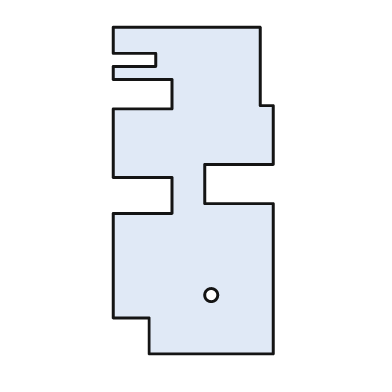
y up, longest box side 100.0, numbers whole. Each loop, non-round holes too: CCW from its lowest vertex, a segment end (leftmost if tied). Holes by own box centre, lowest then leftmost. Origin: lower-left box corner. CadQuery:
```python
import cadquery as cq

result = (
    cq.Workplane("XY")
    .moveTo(11.0, 0.0)
    .lineTo(49.0, 0.0)
    .lineTo(49.0, 46.0)
    .lineTo(28.0, 46.0)
    .lineTo(28.0, 58.0)
    .lineTo(49.0, 58.0)
    .lineTo(49.0, 76.0)
    .lineTo(45.0, 76.0)
    .lineTo(45.0, 100.0)
    .lineTo(0.0, 100.0)
    .lineTo(0.0, 92.0)
    .lineTo(13.0, 92.0)
    .lineTo(13.0, 88.0)
    .lineTo(0.0, 88.0)
    .lineTo(0.0, 84.0)
    .lineTo(18.0, 84.0)
    .lineTo(18.0, 75.0)
    .lineTo(0.0, 75.0)
    .lineTo(0.0, 54.0)
    .lineTo(18.0, 54.0)
    .lineTo(18.0, 43.0)
    .lineTo(0.0, 43.0)
    .lineTo(0.0, 11.0)
    .lineTo(11.0, 11.0)
    .close()
    .moveTo(30.0, 18.0)
    .circle(2.0)
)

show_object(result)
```